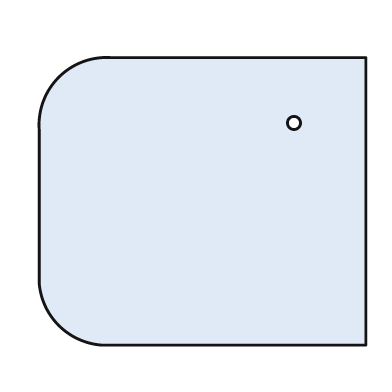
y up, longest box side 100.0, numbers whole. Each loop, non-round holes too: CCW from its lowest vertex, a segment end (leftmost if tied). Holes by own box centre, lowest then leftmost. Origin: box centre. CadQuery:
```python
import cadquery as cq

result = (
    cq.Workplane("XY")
    .moveTo(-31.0, -44.0)
    .lineTo(50.0, -44.0)
    .lineTo(50.0, 44.0)
    .lineTo(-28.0, 44.0)
    .threePointArc((-44.0, 38.0), (-50.0, 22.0))
    .lineTo(-50.0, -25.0)
    .threePointArc((-44.0, -38.0), (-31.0, -44.0))
    .close()
    .moveTo(28.0, 24.0)
    .circle(2.0)
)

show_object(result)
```